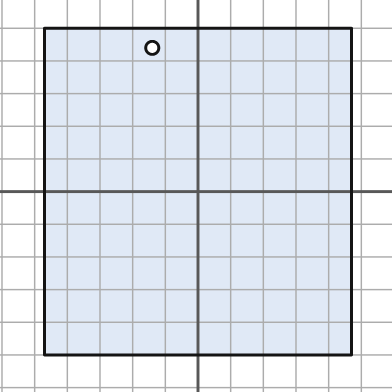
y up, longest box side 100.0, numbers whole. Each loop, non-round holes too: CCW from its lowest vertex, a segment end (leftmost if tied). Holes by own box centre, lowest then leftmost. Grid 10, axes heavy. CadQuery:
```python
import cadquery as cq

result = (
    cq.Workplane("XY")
    .moveTo(-47.0, -50.0)
    .lineTo(47.0, -50.0)
    .lineTo(47.0, 50.0)
    .lineTo(-47.0, 50.0)
    .close()
    .moveTo(-14.0, 44.0)
    .circle(2.0)
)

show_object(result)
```